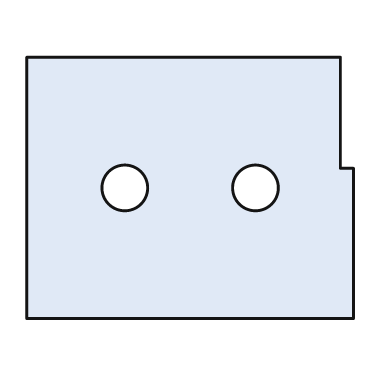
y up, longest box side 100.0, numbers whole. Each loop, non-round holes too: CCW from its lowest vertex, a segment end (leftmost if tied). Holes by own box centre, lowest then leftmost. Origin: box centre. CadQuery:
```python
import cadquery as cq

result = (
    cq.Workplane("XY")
    .moveTo(-50.0, -40.0)
    .lineTo(50.0, -40.0)
    .lineTo(50.0, 6.0)
    .lineTo(46.0, 6.0)
    .lineTo(46.0, 40.0)
    .lineTo(-50.0, 40.0)
    .close()
    .moveTo(-20.0, 0.0)
    .circle(7.0)
    .moveTo(20.0, 0.0)
    .circle(7.0)
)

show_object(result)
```